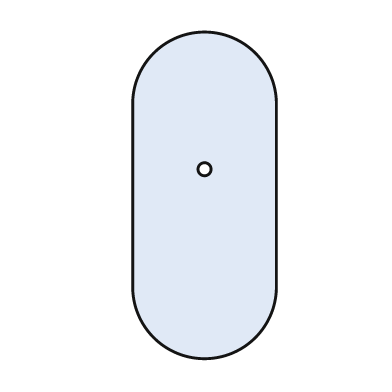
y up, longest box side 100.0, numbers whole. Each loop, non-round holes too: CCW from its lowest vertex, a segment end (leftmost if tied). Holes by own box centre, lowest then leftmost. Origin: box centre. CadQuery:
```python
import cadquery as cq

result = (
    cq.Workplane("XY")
    .moveTo(-22.0, -28.0)
    .threePointArc((0.0, -50.0), (22.0, -28.0))
    .lineTo(22.0, 28.0)
    .threePointArc((0.0, 50.0), (-22.0, 28.0))
    .close()
    .moveTo(0.0, 8.0)
    .circle(2.0)
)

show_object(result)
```